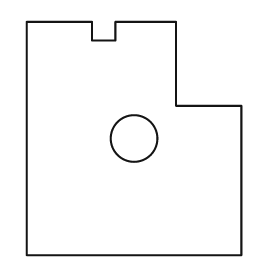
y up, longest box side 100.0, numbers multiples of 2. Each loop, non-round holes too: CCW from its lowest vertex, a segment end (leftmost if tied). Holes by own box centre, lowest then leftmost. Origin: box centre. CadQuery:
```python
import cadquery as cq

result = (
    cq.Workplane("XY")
    .moveTo(-46.0, -50.0)
    .lineTo(46.0, -50.0)
    .lineTo(46.0, 14.0)
    .lineTo(18.0, 14.0)
    .lineTo(18.0, 50.0)
    .lineTo(-8.0, 50.0)
    .lineTo(-8.0, 42.0)
    .lineTo(-18.0, 42.0)
    .lineTo(-18.0, 50.0)
    .lineTo(-46.0, 50.0)
    .close()
    .moveTo(0.0, 0.0)
    .circle(10.0)
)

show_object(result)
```